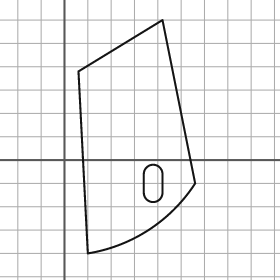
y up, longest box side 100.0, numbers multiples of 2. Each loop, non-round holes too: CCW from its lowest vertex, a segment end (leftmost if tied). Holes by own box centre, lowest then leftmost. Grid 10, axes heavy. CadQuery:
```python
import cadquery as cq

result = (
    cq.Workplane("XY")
    .moveTo(10.0, -40.0)
    .threePointArc((36.0, -30.0), (56.0, -10.0))
    .lineTo(42.0, 60.0)
    .lineTo(6.0, 38.0)
    .close()
    .moveTo(34.0, -14.0)
    .threePointArc((38.0, -18.0), (42.0, -14.0))
    .lineTo(42.0, -6.0)
    .threePointArc((38.0, -2.0), (34.0, -6.0))
    .close()
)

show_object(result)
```